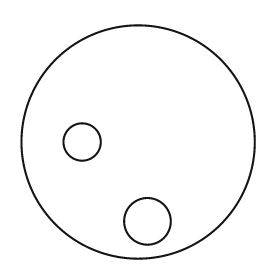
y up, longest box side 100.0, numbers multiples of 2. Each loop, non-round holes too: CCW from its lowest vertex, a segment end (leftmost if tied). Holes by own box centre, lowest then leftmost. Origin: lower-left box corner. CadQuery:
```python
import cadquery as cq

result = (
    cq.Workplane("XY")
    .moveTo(50.0, 50.0)
    .circle(50.0)
    .moveTo(54.0, 16.0)
    .circle(10.0)
    .moveTo(26.0, 50.0)
    .circle(8.0)
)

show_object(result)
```